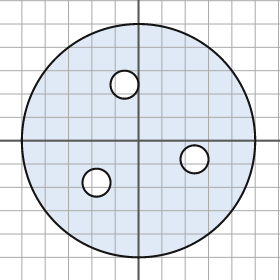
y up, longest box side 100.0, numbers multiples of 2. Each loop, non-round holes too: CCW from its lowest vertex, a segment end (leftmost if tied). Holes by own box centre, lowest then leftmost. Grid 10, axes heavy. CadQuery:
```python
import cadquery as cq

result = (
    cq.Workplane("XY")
    .moveTo(0.0, 0.0)
    .circle(50.0)
    .moveTo(-18.0, -18.0)
    .circle(6.0)
    .moveTo(24.0, -8.0)
    .circle(6.0)
    .moveTo(-6.0, 24.0)
    .circle(6.0)
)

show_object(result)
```